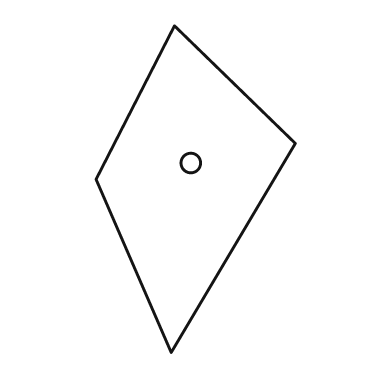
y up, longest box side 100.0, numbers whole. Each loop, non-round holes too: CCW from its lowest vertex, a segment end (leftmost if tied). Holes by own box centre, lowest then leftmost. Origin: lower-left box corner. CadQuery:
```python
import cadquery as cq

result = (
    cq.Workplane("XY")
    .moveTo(23.0, 0.0)
    .lineTo(61.0, 64.0)
    .lineTo(24.0, 100.0)
    .lineTo(0.0, 53.0)
    .close()
    .moveTo(29.0, 58.0)
    .circle(3.0)
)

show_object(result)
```